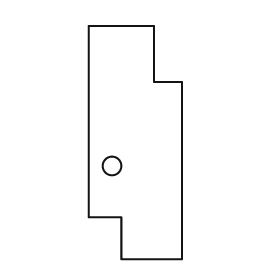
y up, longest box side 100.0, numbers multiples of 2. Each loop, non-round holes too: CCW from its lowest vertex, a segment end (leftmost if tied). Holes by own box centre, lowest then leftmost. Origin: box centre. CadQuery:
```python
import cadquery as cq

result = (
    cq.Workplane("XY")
    .moveTo(-6.0, -50.0)
    .lineTo(20.0, -50.0)
    .lineTo(20.0, 26.0)
    .lineTo(8.0, 26.0)
    .lineTo(8.0, 50.0)
    .lineTo(-20.0, 50.0)
    .lineTo(-20.0, -32.0)
    .lineTo(-6.0, -32.0)
    .close()
    .moveTo(-10.0, -10.0)
    .circle(4.0)
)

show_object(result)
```